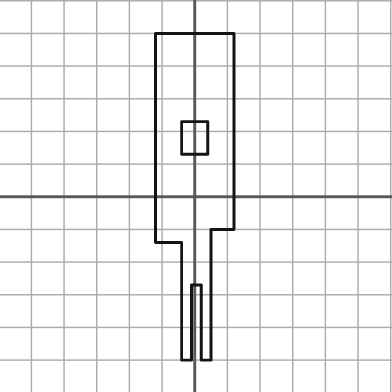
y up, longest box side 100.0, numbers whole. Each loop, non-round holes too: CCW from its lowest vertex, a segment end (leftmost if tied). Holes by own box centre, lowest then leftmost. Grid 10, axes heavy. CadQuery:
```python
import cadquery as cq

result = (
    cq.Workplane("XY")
    .moveTo(-4.0, -50.0)
    .lineTo(-1.0, -50.0)
    .lineTo(-1.0, -27.0)
    .lineTo(2.0, -27.0)
    .lineTo(2.0, -50.0)
    .lineTo(5.0, -50.0)
    .lineTo(5.0, -10.0)
    .lineTo(12.0, -10.0)
    .lineTo(12.0, 50.0)
    .lineTo(-12.0, 50.0)
    .lineTo(-12.0, -14.0)
    .lineTo(-4.0, -14.0)
    .close()
    .moveTo(-4.0, 13.0)
    .lineTo(4.0, 13.0)
    .lineTo(4.0, 23.0)
    .lineTo(-4.0, 23.0)
    .close()
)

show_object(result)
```